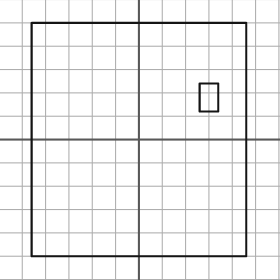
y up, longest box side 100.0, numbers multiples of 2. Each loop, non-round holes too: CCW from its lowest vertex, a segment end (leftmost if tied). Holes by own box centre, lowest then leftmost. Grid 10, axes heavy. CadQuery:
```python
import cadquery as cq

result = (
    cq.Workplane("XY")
    .moveTo(-46.0, -50.0)
    .lineTo(46.0, -50.0)
    .lineTo(46.0, 50.0)
    .lineTo(-46.0, 50.0)
    .close()
    .moveTo(26.0, 12.0)
    .lineTo(34.0, 12.0)
    .lineTo(34.0, 24.0)
    .lineTo(26.0, 24.0)
    .close()
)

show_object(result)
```